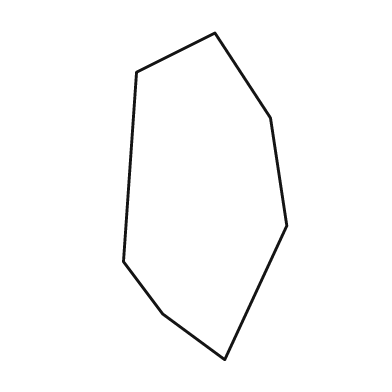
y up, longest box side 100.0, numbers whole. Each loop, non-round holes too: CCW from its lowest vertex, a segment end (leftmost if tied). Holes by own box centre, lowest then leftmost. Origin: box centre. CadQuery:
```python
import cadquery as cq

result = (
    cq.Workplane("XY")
    .moveTo(6.0, -50.0)
    .lineTo(25.0, -9.0)
    .lineTo(20.0, 24.0)
    .lineTo(3.0, 50.0)
    .lineTo(-21.0, 38.0)
    .lineTo(-25.0, -20.0)
    .lineTo(-13.0, -36.0)
    .close()
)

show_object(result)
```